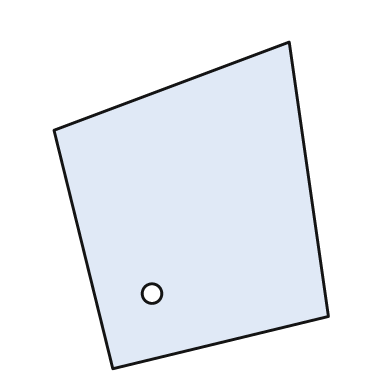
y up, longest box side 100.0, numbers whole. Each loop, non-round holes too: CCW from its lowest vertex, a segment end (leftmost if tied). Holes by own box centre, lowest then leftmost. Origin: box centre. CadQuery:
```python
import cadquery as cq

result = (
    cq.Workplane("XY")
    .moveTo(-24.0, -50.0)
    .lineTo(42.0, -34.0)
    .lineTo(30.0, 50.0)
    .lineTo(-42.0, 23.0)
    .close()
    .moveTo(-12.0, -27.0)
    .circle(3.0)
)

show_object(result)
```